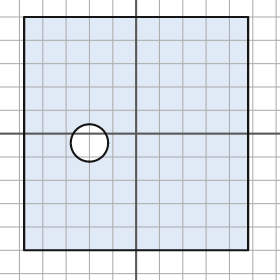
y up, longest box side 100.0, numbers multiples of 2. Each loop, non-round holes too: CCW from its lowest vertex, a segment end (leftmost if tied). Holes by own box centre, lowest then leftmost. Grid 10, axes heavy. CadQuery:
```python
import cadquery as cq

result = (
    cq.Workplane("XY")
    .moveTo(-48.0, -50.0)
    .lineTo(48.0, -50.0)
    .lineTo(48.0, 50.0)
    .lineTo(-48.0, 50.0)
    .close()
    .moveTo(-20.0, -4.0)
    .circle(8.0)
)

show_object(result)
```